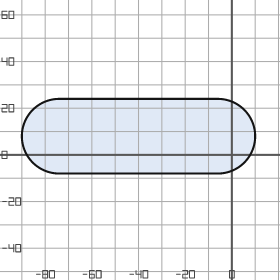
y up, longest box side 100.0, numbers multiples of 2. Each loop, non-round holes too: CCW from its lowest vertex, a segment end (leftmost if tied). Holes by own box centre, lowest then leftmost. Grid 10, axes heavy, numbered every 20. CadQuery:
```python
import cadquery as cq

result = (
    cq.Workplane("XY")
    .moveTo(-74.0, -8.0)
    .lineTo(-6.0, -8.0)
    .threePointArc((10.0, 8.0), (-6.0, 24.0))
    .lineTo(-74.0, 24.0)
    .threePointArc((-90.0, 8.0), (-74.0, -8.0))
    .close()
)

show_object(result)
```